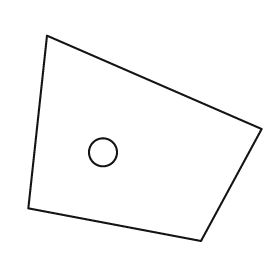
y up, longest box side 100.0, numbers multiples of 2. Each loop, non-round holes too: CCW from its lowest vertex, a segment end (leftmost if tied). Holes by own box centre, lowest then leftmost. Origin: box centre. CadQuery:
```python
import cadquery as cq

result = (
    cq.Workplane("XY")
    .moveTo(24.0, -44.0)
    .lineTo(50.0, 4.0)
    .lineTo(-42.0, 44.0)
    .lineTo(-50.0, -30.0)
    .close()
    .moveTo(-18.0, -6.0)
    .circle(6.0)
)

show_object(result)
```